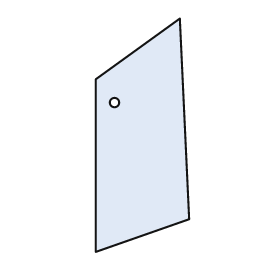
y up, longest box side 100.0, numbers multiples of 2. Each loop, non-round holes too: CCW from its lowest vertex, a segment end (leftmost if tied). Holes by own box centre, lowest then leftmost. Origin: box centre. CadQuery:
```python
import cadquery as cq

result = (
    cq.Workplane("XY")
    .moveTo(-20.0, -50.0)
    .lineTo(20.0, -36.0)
    .lineTo(16.0, 50.0)
    .lineTo(-20.0, 24.0)
    .close()
    .moveTo(-12.0, 14.0)
    .circle(2.0)
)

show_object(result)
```